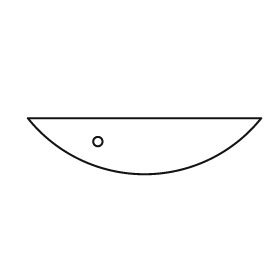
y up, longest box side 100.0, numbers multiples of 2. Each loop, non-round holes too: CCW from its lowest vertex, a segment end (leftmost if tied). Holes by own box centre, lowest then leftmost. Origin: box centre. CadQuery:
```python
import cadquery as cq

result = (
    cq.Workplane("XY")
    .moveTo(-50.0, 12.0)
    .threePointArc((0.0, -12.0), (50.0, 12.0))
    .close()
    .moveTo(-20.0, 2.0)
    .circle(2.0)
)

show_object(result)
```